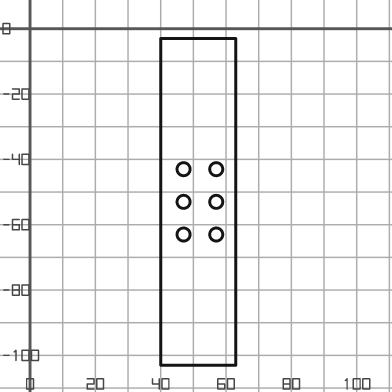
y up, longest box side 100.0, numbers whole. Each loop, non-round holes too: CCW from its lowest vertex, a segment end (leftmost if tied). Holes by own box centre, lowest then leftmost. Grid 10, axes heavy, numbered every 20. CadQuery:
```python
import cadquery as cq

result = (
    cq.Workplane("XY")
    .moveTo(40.0, -103.0)
    .lineTo(63.0, -103.0)
    .lineTo(63.0, -3.0)
    .lineTo(40.0, -3.0)
    .close()
    .moveTo(47.0, -63.0)
    .circle(2.0)
    .moveTo(57.0, -63.0)
    .circle(2.0)
    .moveTo(47.0, -53.0)
    .circle(2.0)
    .moveTo(57.0, -53.0)
    .circle(2.0)
    .moveTo(47.0, -43.0)
    .circle(2.0)
    .moveTo(57.0, -43.0)
    .circle(2.0)
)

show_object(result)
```